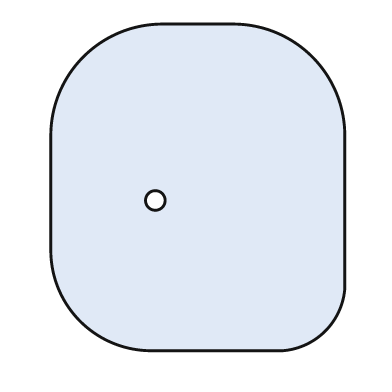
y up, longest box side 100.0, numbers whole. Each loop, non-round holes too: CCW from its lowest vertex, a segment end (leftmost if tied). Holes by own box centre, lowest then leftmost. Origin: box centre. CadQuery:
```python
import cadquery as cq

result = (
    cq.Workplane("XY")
    .moveTo(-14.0, -50.0)
    .lineTo(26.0, -50.0)
    .threePointArc((39.0, -44.0), (45.0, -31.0))
    .lineTo(45.0, 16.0)
    .threePointArc((35.0, 40.0), (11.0, 50.0))
    .lineTo(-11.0, 50.0)
    .threePointArc((-35.0, 40.0), (-45.0, 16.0))
    .lineTo(-45.0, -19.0)
    .threePointArc((-36.0, -41.0), (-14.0, -50.0))
    .close()
    .moveTo(-13.0, -4.0)
    .circle(3.0)
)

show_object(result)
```